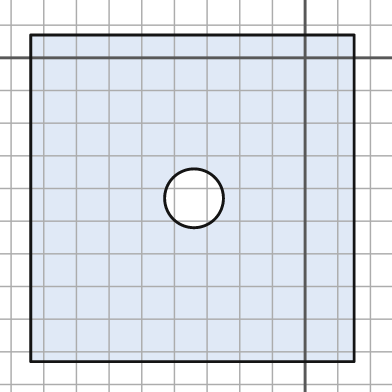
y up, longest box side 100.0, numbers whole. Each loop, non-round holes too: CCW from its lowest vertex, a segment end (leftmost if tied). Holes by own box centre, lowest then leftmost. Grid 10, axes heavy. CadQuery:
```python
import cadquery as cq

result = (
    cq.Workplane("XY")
    .moveTo(-84.0, -93.0)
    .lineTo(15.0, -93.0)
    .lineTo(15.0, 7.0)
    .lineTo(-84.0, 7.0)
    .close()
    .moveTo(-34.0, -43.0)
    .circle(9.0)
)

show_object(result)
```